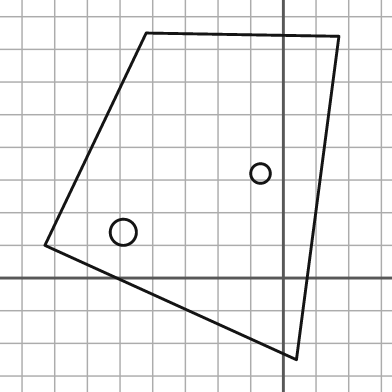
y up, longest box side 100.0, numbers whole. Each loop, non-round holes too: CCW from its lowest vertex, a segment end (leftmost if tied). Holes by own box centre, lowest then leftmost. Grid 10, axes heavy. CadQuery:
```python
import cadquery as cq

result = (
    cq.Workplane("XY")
    .moveTo(4.0, -25.0)
    .lineTo(17.0, 74.0)
    .lineTo(-42.0, 75.0)
    .lineTo(-73.0, 10.0)
    .close()
    .moveTo(-49.0, 14.0)
    .circle(4.0)
    .moveTo(-7.0, 32.0)
    .circle(3.0)
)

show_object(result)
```